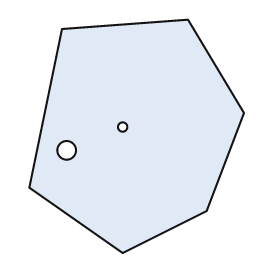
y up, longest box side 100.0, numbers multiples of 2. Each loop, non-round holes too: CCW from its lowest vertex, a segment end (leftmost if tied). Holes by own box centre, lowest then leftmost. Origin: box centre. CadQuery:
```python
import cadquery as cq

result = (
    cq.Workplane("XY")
    .moveTo(-6.0, -50.0)
    .lineTo(30.0, -32.0)
    .lineTo(46.0, 10.0)
    .lineTo(22.0, 50.0)
    .lineTo(-32.0, 46.0)
    .lineTo(-46.0, -22.0)
    .close()
    .moveTo(-30.0, -6.0)
    .circle(4.0)
    .moveTo(-6.0, 4.0)
    .circle(2.0)
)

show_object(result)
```